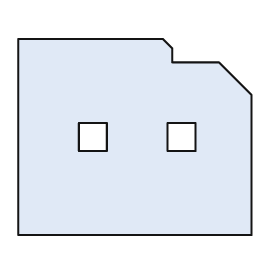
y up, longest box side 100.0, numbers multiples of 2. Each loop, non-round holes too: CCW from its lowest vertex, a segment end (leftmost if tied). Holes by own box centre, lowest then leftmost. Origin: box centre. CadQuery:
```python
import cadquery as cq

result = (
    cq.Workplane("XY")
    .moveTo(-50.0, -42.0)
    .lineTo(50.0, -42.0)
    .lineTo(50.0, 18.0)
    .lineTo(36.0, 32.0)
    .lineTo(16.0, 32.0)
    .lineTo(16.0, 38.0)
    .lineTo(12.0, 42.0)
    .lineTo(-50.0, 42.0)
    .close()
    .moveTo(-24.0, -6.0)
    .lineTo(-12.0, -6.0)
    .lineTo(-12.0, 6.0)
    .lineTo(-24.0, 6.0)
    .close()
    .moveTo(14.0, -6.0)
    .lineTo(26.0, -6.0)
    .lineTo(26.0, 6.0)
    .lineTo(14.0, 6.0)
    .close()
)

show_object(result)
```